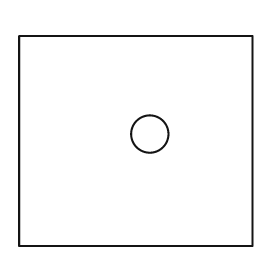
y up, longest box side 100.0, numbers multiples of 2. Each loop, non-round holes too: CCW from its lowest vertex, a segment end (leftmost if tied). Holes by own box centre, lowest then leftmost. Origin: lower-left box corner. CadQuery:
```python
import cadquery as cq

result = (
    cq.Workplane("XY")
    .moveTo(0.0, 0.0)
    .lineTo(100.0, 0.0)
    .lineTo(100.0, 90.0)
    .lineTo(0.0, 90.0)
    .close()
    .moveTo(56.0, 48.0)
    .circle(8.0)
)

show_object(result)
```